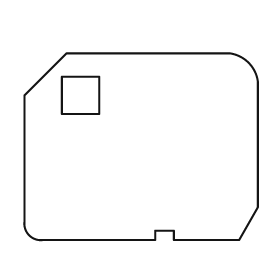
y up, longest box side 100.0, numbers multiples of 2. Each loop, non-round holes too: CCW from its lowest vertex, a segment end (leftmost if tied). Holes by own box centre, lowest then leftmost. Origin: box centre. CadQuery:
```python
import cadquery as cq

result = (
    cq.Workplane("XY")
    .moveTo(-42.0, -40.0)
    .lineTo(6.0, -40.0)
    .lineTo(6.0, -36.0)
    .lineTo(14.0, -36.0)
    .lineTo(14.0, -40.0)
    .lineTo(42.0, -40.0)
    .lineTo(50.0, -26.0)
    .lineTo(50.0, 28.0)
    .threePointArc((46.0, 36.0), (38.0, 40.0))
    .lineTo(-32.0, 40.0)
    .lineTo(-50.0, 22.0)
    .lineTo(-50.0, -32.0)
    .threePointArc((-48.0, -38.0), (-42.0, -40.0))
    .close()
    .moveTo(-34.0, 14.0)
    .lineTo(-18.0, 14.0)
    .lineTo(-18.0, 30.0)
    .lineTo(-34.0, 30.0)
    .close()
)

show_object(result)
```